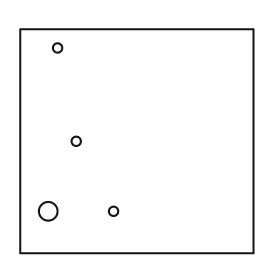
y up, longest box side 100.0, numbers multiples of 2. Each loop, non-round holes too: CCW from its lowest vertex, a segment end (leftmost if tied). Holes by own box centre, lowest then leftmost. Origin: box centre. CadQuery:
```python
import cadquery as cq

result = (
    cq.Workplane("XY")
    .moveTo(-50.0, -48.0)
    .lineTo(50.0, -48.0)
    .lineTo(50.0, 48.0)
    .lineTo(-50.0, 48.0)
    .close()
    .moveTo(-38.0, -30.0)
    .circle(4.0)
    .moveTo(-10.0, -30.0)
    .circle(2.0)
    .moveTo(-26.0, 0.0)
    .circle(2.0)
    .moveTo(-34.0, 40.0)
    .circle(2.0)
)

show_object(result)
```